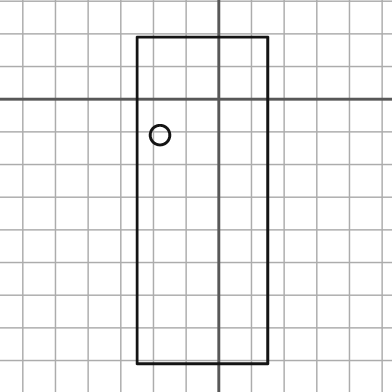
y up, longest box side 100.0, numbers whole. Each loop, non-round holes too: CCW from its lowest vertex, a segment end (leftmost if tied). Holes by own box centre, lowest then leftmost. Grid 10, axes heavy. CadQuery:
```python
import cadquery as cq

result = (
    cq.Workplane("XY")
    .moveTo(-25.0, -81.0)
    .lineTo(15.0, -81.0)
    .lineTo(15.0, 19.0)
    .lineTo(-25.0, 19.0)
    .close()
    .moveTo(-18.0, -11.0)
    .circle(3.0)
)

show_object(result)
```